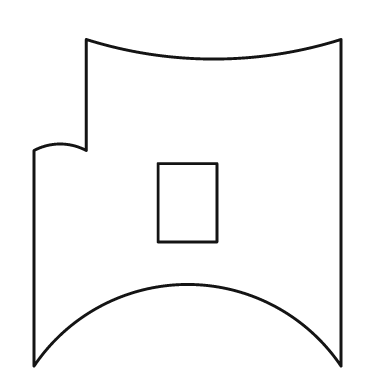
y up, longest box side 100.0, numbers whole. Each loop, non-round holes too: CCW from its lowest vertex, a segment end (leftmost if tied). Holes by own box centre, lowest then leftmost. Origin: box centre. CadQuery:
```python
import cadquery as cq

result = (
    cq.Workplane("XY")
    .moveTo(-47.0, -50.0)
    .threePointArc((0.0, -25.0), (47.0, -50.0))
    .lineTo(47.0, 50.0)
    .threePointArc((8.0, 44.0), (-31.0, 50.0))
    .lineTo(-31.0, 16.0)
    .threePointArc((-39.0, 18.0), (-47.0, 16.0))
    .close()
    .moveTo(-9.0, -12.0)
    .lineTo(9.0, -12.0)
    .lineTo(9.0, 12.0)
    .lineTo(-9.0, 12.0)
    .close()
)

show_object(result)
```